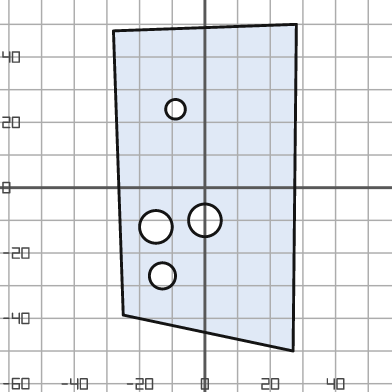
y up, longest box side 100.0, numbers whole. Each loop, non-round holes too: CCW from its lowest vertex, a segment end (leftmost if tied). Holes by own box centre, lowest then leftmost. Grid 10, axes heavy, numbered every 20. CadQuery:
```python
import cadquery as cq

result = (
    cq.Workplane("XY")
    .moveTo(27.0, -50.0)
    .lineTo(28.0, 50.0)
    .lineTo(-28.0, 48.0)
    .lineTo(-25.0, -39.0)
    .close()
    .moveTo(-13.0, -27.0)
    .circle(4.0)
    .moveTo(-15.0, -12.0)
    .circle(5.0)
    .moveTo(0.0, -10.0)
    .circle(5.0)
    .moveTo(-9.0, 24.0)
    .circle(3.0)
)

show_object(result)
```